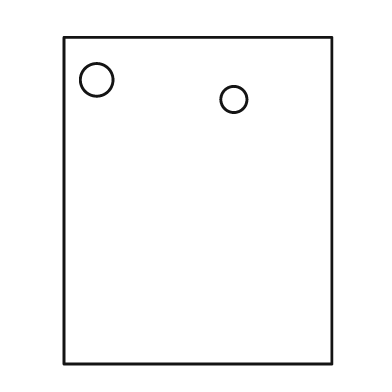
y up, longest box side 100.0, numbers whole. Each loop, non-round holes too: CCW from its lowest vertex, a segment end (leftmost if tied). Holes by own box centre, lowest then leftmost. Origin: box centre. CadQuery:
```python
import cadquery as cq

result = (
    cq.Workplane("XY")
    .moveTo(-41.0, -50.0)
    .lineTo(41.0, -50.0)
    .lineTo(41.0, 50.0)
    .lineTo(-41.0, 50.0)
    .close()
    .moveTo(11.0, 31.0)
    .circle(4.0)
    .moveTo(-31.0, 37.0)
    .circle(5.0)
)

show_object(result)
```